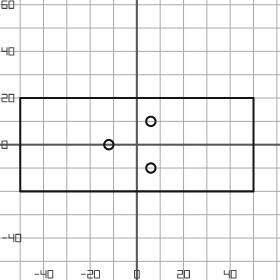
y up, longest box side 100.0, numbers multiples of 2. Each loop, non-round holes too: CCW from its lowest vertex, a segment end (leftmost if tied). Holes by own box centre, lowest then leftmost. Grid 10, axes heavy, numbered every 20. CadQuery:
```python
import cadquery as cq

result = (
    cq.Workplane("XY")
    .moveTo(-50.0, -20.0)
    .lineTo(50.0, -20.0)
    .lineTo(50.0, 20.0)
    .lineTo(-50.0, 20.0)
    .close()
    .moveTo(6.0, -10.0)
    .circle(2.0)
    .moveTo(-12.0, 0.0)
    .circle(2.0)
    .moveTo(6.0, 10.0)
    .circle(2.0)
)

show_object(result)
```